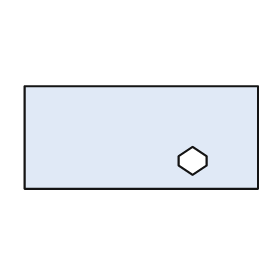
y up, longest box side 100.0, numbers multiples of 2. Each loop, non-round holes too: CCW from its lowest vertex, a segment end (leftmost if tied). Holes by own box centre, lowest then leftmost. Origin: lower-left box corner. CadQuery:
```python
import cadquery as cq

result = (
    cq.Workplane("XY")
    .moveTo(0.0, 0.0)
    .lineTo(100.0, 0.0)
    .lineTo(100.0, 44.0)
    .lineTo(0.0, 44.0)
    .close()
    .moveTo(72.0, 6.0)
    .lineTo(78.0, 10.0)
    .lineTo(78.0, 14.0)
    .lineTo(72.0, 18.0)
    .lineTo(66.0, 14.0)
    .lineTo(66.0, 10.0)
    .close()
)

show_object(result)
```